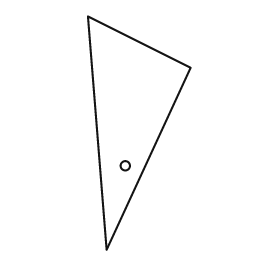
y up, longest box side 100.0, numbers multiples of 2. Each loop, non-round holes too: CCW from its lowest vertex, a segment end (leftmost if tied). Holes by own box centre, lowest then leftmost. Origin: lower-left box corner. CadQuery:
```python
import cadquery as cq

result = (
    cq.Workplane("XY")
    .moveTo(8.0, 0.0)
    .lineTo(44.0, 78.0)
    .lineTo(0.0, 100.0)
    .close()
    .moveTo(16.0, 36.0)
    .circle(2.0)
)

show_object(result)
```